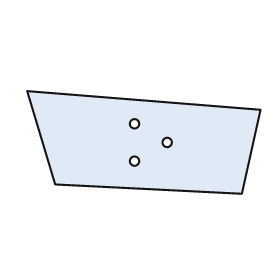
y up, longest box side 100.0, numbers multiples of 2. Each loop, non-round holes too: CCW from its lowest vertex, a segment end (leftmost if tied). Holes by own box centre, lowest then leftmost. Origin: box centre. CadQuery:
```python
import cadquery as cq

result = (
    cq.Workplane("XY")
    .moveTo(42.0, -22.0)
    .lineTo(50.0, 14.0)
    .lineTo(-50.0, 22.0)
    .lineTo(-38.0, -18.0)
    .close()
    .moveTo(-4.0, -8.0)
    .circle(2.0)
    .moveTo(10.0, 0.0)
    .circle(2.0)
    .moveTo(-4.0, 8.0)
    .circle(2.0)
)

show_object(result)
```